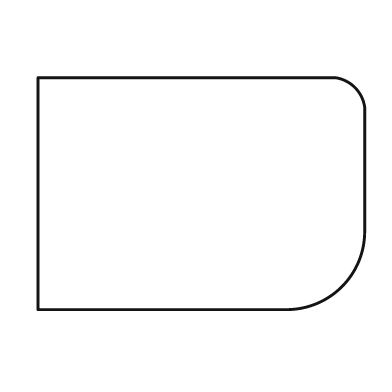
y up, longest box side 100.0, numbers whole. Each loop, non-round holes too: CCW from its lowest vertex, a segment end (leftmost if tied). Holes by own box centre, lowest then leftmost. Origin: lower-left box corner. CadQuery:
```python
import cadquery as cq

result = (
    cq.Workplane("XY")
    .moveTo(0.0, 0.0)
    .lineTo(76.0, 0.0)
    .threePointArc((93.0, 7.0), (100.0, 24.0))
    .lineTo(100.0, 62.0)
    .threePointArc((97.0, 68.0), (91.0, 71.0))
    .lineTo(0.0, 71.0)
    .close()
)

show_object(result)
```